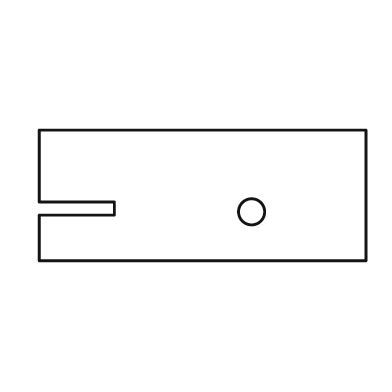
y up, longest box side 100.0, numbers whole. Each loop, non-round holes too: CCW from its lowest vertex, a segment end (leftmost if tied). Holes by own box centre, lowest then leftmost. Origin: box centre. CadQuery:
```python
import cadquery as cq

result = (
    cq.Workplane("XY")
    .moveTo(-50.0, -20.0)
    .lineTo(50.0, -20.0)
    .lineTo(50.0, 20.0)
    .lineTo(-50.0, 20.0)
    .lineTo(-50.0, -2.0)
    .lineTo(-27.0, -2.0)
    .lineTo(-27.0, -6.0)
    .lineTo(-50.0, -6.0)
    .close()
    .moveTo(15.0, -5.0)
    .circle(4.0)
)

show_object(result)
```